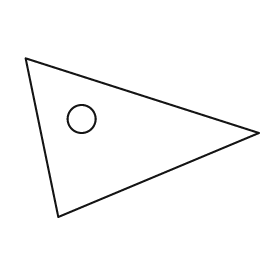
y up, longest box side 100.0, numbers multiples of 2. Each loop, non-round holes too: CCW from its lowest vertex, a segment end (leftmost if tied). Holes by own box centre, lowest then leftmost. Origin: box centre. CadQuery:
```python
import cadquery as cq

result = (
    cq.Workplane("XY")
    .moveTo(-36.0, -34.0)
    .lineTo(50.0, 2.0)
    .lineTo(-50.0, 34.0)
    .close()
    .moveTo(-26.0, 8.0)
    .circle(6.0)
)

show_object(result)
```